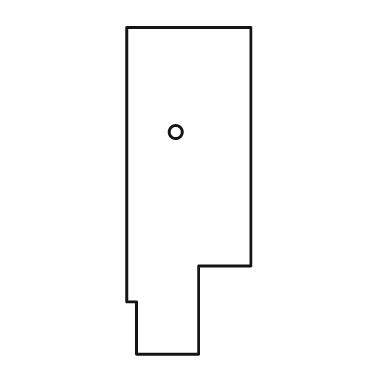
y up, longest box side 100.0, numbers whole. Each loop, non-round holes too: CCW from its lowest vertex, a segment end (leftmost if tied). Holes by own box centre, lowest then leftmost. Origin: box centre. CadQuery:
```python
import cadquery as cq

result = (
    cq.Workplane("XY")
    .moveTo(-16.0, -50.0)
    .lineTo(3.0, -50.0)
    .lineTo(3.0, -23.0)
    .lineTo(19.0, -23.0)
    .lineTo(19.0, 50.0)
    .lineTo(-19.0, 50.0)
    .lineTo(-19.0, -34.0)
    .lineTo(-16.0, -34.0)
    .close()
    .moveTo(-4.0, 18.0)
    .circle(2.0)
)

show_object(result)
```